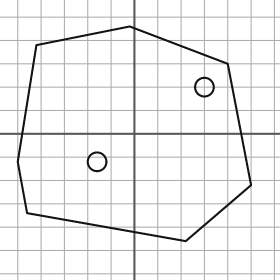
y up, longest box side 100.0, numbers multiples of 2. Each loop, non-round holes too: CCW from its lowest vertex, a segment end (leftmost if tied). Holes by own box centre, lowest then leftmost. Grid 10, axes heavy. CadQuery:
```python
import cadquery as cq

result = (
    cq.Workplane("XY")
    .moveTo(22.0, -46.0)
    .lineTo(50.0, -22.0)
    .lineTo(40.0, 30.0)
    .lineTo(-2.0, 46.0)
    .lineTo(-42.0, 38.0)
    .lineTo(-50.0, -12.0)
    .lineTo(-46.0, -34.0)
    .close()
    .moveTo(-16.0, -12.0)
    .circle(4.0)
    .moveTo(30.0, 20.0)
    .circle(4.0)
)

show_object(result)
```